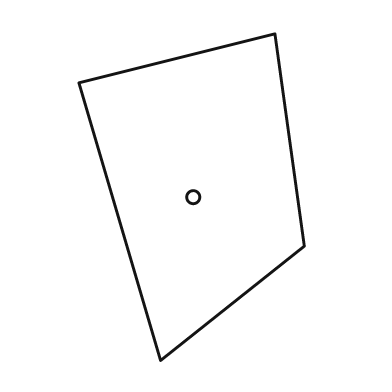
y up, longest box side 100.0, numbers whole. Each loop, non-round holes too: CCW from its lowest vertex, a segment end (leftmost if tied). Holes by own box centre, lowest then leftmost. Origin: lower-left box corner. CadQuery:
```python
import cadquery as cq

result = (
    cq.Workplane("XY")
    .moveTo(25.0, 0.0)
    .lineTo(69.0, 35.0)
    .lineTo(60.0, 100.0)
    .lineTo(0.0, 85.0)
    .close()
    .moveTo(35.0, 50.0)
    .circle(2.0)
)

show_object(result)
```